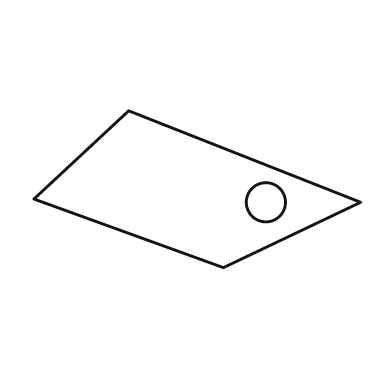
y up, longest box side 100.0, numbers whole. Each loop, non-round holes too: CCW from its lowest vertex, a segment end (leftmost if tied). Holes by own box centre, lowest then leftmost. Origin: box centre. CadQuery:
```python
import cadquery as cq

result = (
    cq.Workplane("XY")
    .moveTo(8.0, -24.0)
    .lineTo(50.0, -4.0)
    .lineTo(-21.0, 24.0)
    .lineTo(-50.0, -3.0)
    .close()
    .moveTo(21.0, -4.0)
    .circle(6.0)
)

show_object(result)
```